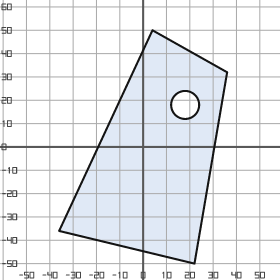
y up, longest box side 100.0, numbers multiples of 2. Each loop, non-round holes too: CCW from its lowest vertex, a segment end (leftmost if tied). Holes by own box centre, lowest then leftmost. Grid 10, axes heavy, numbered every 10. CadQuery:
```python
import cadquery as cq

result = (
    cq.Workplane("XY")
    .moveTo(22.0, -50.0)
    .lineTo(36.0, 32.0)
    .lineTo(4.0, 50.0)
    .lineTo(-36.0, -36.0)
    .close()
    .moveTo(18.0, 18.0)
    .circle(6.0)
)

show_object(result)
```